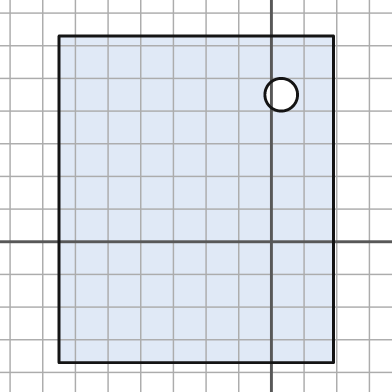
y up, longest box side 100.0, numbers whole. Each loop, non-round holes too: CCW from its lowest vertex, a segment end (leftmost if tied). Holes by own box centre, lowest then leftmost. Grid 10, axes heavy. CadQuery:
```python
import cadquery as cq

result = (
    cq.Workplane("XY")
    .moveTo(-65.0, -37.0)
    .lineTo(19.0, -37.0)
    .lineTo(19.0, 63.0)
    .lineTo(-65.0, 63.0)
    .close()
    .moveTo(3.0, 45.0)
    .circle(5.0)
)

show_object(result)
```